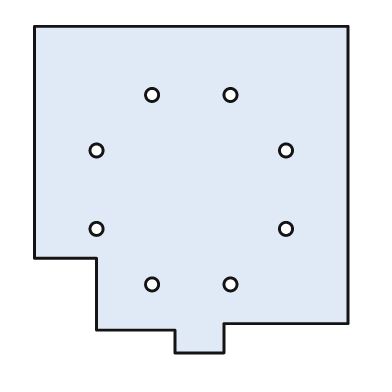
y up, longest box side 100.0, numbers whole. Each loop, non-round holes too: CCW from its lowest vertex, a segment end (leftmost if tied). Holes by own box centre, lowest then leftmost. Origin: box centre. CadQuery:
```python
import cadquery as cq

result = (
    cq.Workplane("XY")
    .moveTo(-5.0, -50.0)
    .lineTo(10.0, -50.0)
    .lineTo(10.0, -41.0)
    .lineTo(48.0, -41.0)
    .lineTo(48.0, 50.0)
    .lineTo(-48.0, 50.0)
    .lineTo(-48.0, -21.0)
    .lineTo(-29.0, -21.0)
    .lineTo(-29.0, -43.0)
    .lineTo(-5.0, -43.0)
    .close()
    .moveTo(-12.0, -29.0)
    .circle(2.0)
    .moveTo(12.0, -29.0)
    .circle(2.0)
    .moveTo(-29.0, -12.0)
    .circle(2.0)
    .moveTo(29.0, -12.0)
    .circle(2.0)
    .moveTo(-29.0, 12.0)
    .circle(2.0)
    .moveTo(29.0, 12.0)
    .circle(2.0)
    .moveTo(-12.0, 29.0)
    .circle(2.0)
    .moveTo(12.0, 29.0)
    .circle(2.0)
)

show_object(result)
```